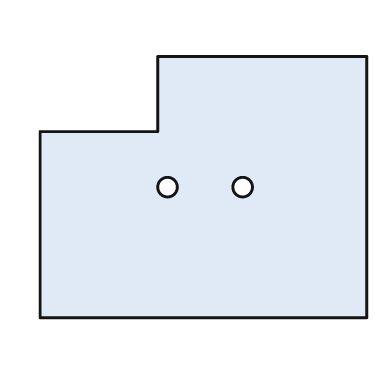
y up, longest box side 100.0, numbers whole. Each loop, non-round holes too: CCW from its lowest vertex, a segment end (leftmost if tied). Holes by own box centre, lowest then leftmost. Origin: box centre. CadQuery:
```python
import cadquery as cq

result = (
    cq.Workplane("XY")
    .moveTo(-50.0, -40.0)
    .lineTo(50.0, -40.0)
    .lineTo(50.0, 40.0)
    .lineTo(-14.0, 40.0)
    .lineTo(-14.0, 17.0)
    .lineTo(-50.0, 17.0)
    .close()
    .moveTo(-11.0, 0.0)
    .circle(3.0)
    .moveTo(12.0, 0.0)
    .circle(3.0)
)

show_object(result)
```